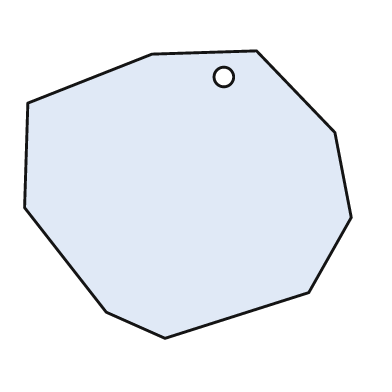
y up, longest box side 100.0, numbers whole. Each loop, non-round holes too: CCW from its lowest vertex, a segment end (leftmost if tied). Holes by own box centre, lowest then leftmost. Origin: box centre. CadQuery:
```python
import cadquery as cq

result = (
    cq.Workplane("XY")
    .moveTo(-7.0, -44.0)
    .lineTo(37.0, -30.0)
    .lineTo(50.0, -7.0)
    .lineTo(45.0, 19.0)
    .lineTo(21.0, 44.0)
    .lineTo(-11.0, 43.0)
    .lineTo(-49.0, 28.0)
    .lineTo(-50.0, -4.0)
    .lineTo(-25.0, -36.0)
    .close()
    .moveTo(11.0, 36.0)
    .circle(3.0)
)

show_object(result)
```